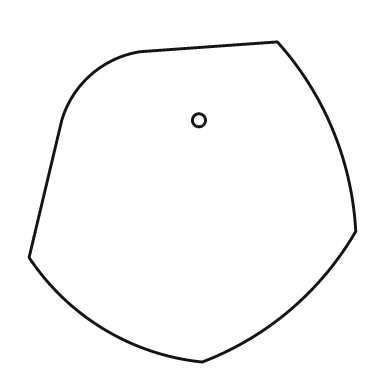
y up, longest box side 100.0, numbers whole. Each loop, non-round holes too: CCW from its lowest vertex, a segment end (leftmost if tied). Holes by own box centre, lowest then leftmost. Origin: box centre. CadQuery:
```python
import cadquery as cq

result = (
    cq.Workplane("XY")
    .moveTo(3.0, -49.0)
    .threePointArc((30.0, -33.0), (50.0, -9.0))
    .threePointArc((43.0, 22.0), (26.0, 49.0))
    .lineTo(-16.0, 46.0)
    .threePointArc((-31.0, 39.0), (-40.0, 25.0))
    .lineTo(-50.0, -17.0)
    .threePointArc((-27.0, -39.0), (3.0, -49.0))
    .close()
    .moveTo(2.0, 25.0)
    .circle(2.0)
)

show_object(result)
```